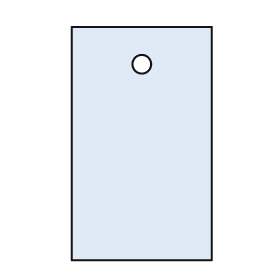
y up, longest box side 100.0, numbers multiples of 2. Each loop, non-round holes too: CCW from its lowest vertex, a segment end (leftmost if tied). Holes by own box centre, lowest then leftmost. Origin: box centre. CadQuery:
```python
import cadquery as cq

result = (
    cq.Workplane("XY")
    .moveTo(-30.0, -50.0)
    .lineTo(30.0, -50.0)
    .lineTo(30.0, 50.0)
    .lineTo(-30.0, 50.0)
    .close()
    .moveTo(0.0, 34.0)
    .circle(4.0)
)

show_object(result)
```